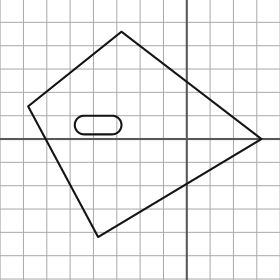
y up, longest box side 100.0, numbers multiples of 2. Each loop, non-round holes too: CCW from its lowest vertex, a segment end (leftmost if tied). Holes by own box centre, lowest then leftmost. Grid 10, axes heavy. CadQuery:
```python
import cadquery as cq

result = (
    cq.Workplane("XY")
    .moveTo(-38.0, -42.0)
    .lineTo(32.0, 0.0)
    .lineTo(-28.0, 46.0)
    .lineTo(-68.0, 14.0)
    .close()
    .moveTo(-44.0, 2.0)
    .lineTo(-32.0, 2.0)
    .threePointArc((-28.0, 6.0), (-32.0, 10.0))
    .lineTo(-44.0, 10.0)
    .threePointArc((-48.0, 6.0), (-44.0, 2.0))
    .close()
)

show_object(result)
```